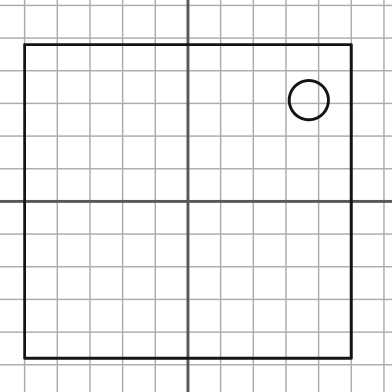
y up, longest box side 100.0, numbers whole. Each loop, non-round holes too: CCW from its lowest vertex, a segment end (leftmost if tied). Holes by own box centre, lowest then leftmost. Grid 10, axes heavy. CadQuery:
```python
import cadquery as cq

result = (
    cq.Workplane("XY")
    .moveTo(-50.0, -48.0)
    .lineTo(50.0, -48.0)
    .lineTo(50.0, 48.0)
    .lineTo(-50.0, 48.0)
    .close()
    .moveTo(37.0, 31.0)
    .circle(6.0)
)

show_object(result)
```